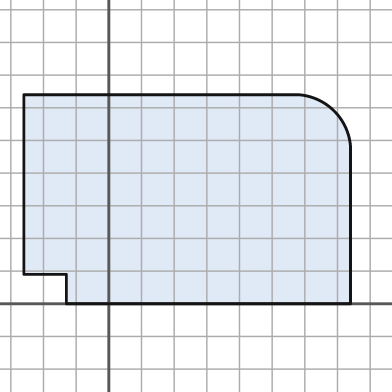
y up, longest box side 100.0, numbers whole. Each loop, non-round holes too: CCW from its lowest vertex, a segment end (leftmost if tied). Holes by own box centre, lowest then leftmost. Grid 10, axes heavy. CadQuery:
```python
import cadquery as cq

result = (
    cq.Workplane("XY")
    .moveTo(-13.0, 0.0)
    .lineTo(74.0, 0.0)
    .lineTo(74.0, 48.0)
    .threePointArc((69.0, 59.0), (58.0, 64.0))
    .lineTo(-26.0, 64.0)
    .lineTo(-26.0, 9.0)
    .lineTo(-13.0, 9.0)
    .close()
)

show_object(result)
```